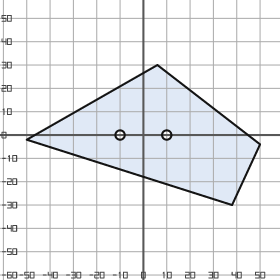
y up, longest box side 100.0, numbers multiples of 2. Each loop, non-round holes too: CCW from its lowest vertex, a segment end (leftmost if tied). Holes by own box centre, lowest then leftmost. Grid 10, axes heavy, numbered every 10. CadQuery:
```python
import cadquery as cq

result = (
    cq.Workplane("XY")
    .moveTo(38.0, -30.0)
    .lineTo(50.0, -4.0)
    .lineTo(6.0, 30.0)
    .lineTo(-50.0, -2.0)
    .close()
    .moveTo(-10.0, 0.0)
    .circle(2.0)
    .moveTo(10.0, 0.0)
    .circle(2.0)
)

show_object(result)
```